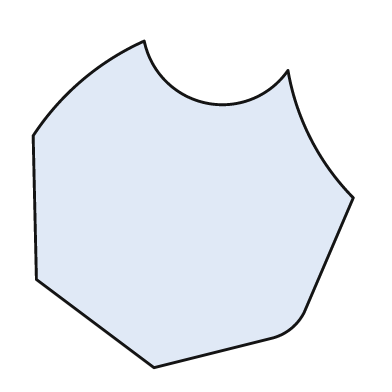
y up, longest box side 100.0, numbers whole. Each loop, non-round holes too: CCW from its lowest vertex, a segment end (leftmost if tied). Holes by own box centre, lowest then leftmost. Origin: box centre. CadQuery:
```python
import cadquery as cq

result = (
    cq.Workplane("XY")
    .moveTo(-12.0, -50.0)
    .lineTo(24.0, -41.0)
    .threePointArc((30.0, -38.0), (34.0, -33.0))
    .lineTo(49.0, 2.0)
    .threePointArc((36.0, 20.0), (29.0, 41.0))
    .threePointArc((4.0, 31.0), (-15.0, 50.0))
    .threePointArc((-34.0, 38.0), (-49.0, 21.0))
    .lineTo(-48.0, -23.0)
    .close()
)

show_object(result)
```